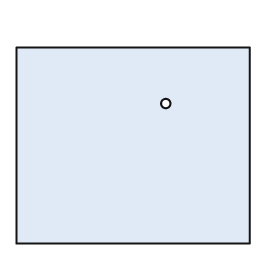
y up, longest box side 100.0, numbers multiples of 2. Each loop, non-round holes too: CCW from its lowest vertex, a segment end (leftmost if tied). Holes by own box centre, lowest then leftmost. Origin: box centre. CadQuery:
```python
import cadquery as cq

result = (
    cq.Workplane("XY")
    .moveTo(-50.0, -42.0)
    .lineTo(50.0, -42.0)
    .lineTo(50.0, 42.0)
    .lineTo(-50.0, 42.0)
    .close()
    .moveTo(14.0, 18.0)
    .circle(2.0)
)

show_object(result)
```